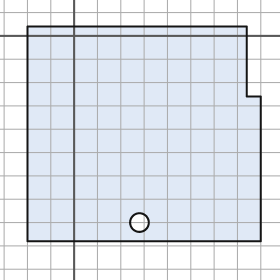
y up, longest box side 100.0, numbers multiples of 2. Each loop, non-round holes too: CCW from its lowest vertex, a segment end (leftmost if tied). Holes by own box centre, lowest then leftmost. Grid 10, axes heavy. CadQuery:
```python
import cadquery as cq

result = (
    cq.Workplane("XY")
    .moveTo(-20.0, -88.0)
    .lineTo(80.0, -88.0)
    .lineTo(80.0, -26.0)
    .lineTo(74.0, -26.0)
    .lineTo(74.0, 4.0)
    .lineTo(-20.0, 4.0)
    .close()
    .moveTo(28.0, -80.0)
    .circle(4.0)
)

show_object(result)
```